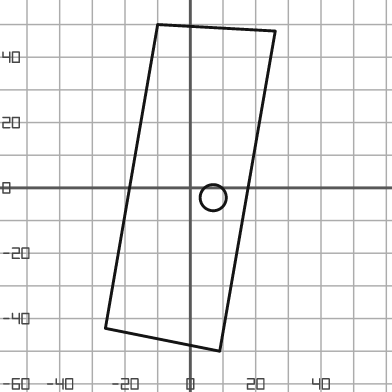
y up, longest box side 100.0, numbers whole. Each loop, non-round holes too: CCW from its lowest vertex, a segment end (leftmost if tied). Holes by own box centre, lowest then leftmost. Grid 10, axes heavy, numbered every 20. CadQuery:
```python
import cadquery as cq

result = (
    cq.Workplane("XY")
    .moveTo(9.0, -50.0)
    .lineTo(26.0, 48.0)
    .lineTo(-10.0, 50.0)
    .lineTo(-26.0, -43.0)
    .close()
    .moveTo(7.0, -3.0)
    .circle(4.0)
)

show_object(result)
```